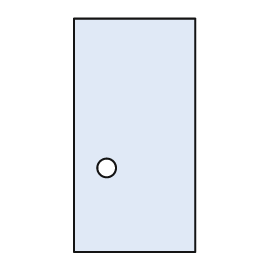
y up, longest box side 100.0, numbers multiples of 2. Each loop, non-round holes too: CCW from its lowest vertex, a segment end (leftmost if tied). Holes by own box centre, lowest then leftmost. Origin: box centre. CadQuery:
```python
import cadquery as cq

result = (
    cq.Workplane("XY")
    .moveTo(-26.0, -50.0)
    .lineTo(26.0, -50.0)
    .lineTo(26.0, 50.0)
    .lineTo(-26.0, 50.0)
    .close()
    .moveTo(-12.0, -14.0)
    .circle(4.0)
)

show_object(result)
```